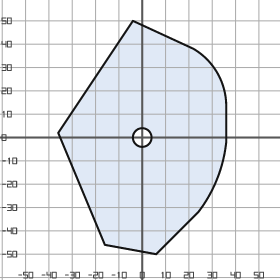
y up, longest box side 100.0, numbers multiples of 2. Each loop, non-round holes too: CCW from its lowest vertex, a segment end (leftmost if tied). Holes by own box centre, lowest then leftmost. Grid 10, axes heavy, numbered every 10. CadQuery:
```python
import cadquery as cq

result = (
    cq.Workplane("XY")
    .moveTo(6.0, -50.0)
    .lineTo(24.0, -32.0)
    .threePointArc((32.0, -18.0), (36.0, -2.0))
    .lineTo(36.0, 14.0)
    .threePointArc((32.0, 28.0), (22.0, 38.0))
    .lineTo(-4.0, 50.0)
    .lineTo(-36.0, 2.0)
    .lineTo(-16.0, -46.0)
    .close()
    .moveTo(0.0, 0.0)
    .circle(4.0)
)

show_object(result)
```